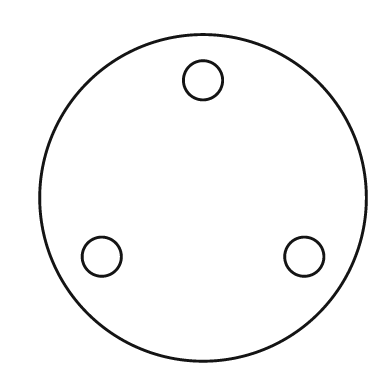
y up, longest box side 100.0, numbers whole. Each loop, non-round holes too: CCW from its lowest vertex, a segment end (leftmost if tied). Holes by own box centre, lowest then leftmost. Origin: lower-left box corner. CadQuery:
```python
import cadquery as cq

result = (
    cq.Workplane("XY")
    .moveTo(50.0, 50.0)
    .circle(50.0)
    .moveTo(19.0, 32.0)
    .circle(6.0)
    .moveTo(81.0, 32.0)
    .circle(6.0)
    .moveTo(50.0, 86.0)
    .circle(6.0)
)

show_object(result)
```